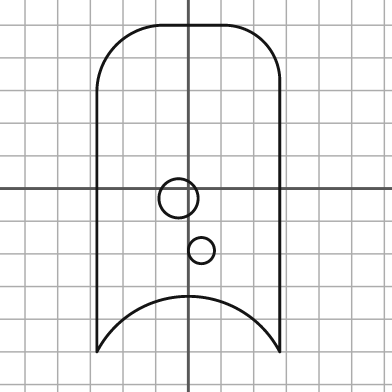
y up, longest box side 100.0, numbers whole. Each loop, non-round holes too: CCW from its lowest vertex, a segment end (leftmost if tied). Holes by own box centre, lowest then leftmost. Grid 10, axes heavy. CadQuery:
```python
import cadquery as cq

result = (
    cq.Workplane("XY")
    .moveTo(-28.0, -50.0)
    .threePointArc((0.0, -33.0), (28.0, -50.0))
    .lineTo(28.0, 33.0)
    .threePointArc((23.0, 45.0), (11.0, 50.0))
    .lineTo(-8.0, 50.0)
    .threePointArc((-22.0, 44.0), (-28.0, 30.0))
    .close()
    .moveTo(4.0, -19.0)
    .circle(4.0)
    .moveTo(-3.0, -3.0)
    .circle(6.0)
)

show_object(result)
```